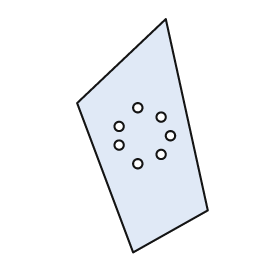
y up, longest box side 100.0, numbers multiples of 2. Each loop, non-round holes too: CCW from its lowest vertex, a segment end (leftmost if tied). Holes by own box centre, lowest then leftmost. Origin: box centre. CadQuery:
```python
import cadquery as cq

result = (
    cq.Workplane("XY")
    .moveTo(-4.0, -50.0)
    .lineTo(28.0, -32.0)
    .lineTo(10.0, 50.0)
    .lineTo(-28.0, 14.0)
    .close()
    .moveTo(-2.0, -12.0)
    .circle(2.0)
    .moveTo(8.0, -8.0)
    .circle(2.0)
    .moveTo(-10.0, -4.0)
    .circle(2.0)
    .moveTo(12.0, 0.0)
    .circle(2.0)
    .moveTo(-10.0, 4.0)
    .circle(2.0)
    .moveTo(8.0, 8.0)
    .circle(2.0)
    .moveTo(-2.0, 12.0)
    .circle(2.0)
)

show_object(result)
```